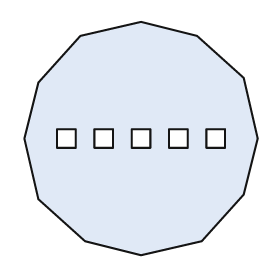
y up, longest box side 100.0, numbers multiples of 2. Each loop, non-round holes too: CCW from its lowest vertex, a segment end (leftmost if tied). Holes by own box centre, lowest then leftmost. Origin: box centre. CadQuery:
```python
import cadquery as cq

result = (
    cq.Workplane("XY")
    .moveTo(0.0, -50.0)
    .lineTo(26.0, -44.0)
    .lineTo(44.0, -24.0)
    .lineTo(50.0, 0.0)
    .lineTo(44.0, 26.0)
    .lineTo(24.0, 44.0)
    .lineTo(0.0, 50.0)
    .lineTo(-26.0, 44.0)
    .lineTo(-44.0, 24.0)
    .lineTo(-50.0, 0.0)
    .lineTo(-44.0, -26.0)
    .lineTo(-24.0, -44.0)
    .close()
    .moveTo(-36.0, -4.0)
    .lineTo(-28.0, -4.0)
    .lineTo(-28.0, 4.0)
    .lineTo(-36.0, 4.0)
    .close()
    .moveTo(-20.0, -4.0)
    .lineTo(-12.0, -4.0)
    .lineTo(-12.0, 4.0)
    .lineTo(-20.0, 4.0)
    .close()
    .moveTo(-4.0, -4.0)
    .lineTo(4.0, -4.0)
    .lineTo(4.0, 4.0)
    .lineTo(-4.0, 4.0)
    .close()
    .moveTo(12.0, -4.0)
    .lineTo(20.0, -4.0)
    .lineTo(20.0, 4.0)
    .lineTo(12.0, 4.0)
    .close()
    .moveTo(28.0, -4.0)
    .lineTo(36.0, -4.0)
    .lineTo(36.0, 4.0)
    .lineTo(28.0, 4.0)
    .close()
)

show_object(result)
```